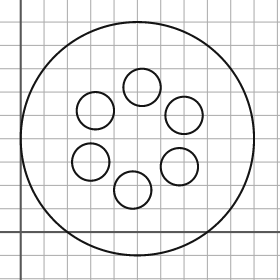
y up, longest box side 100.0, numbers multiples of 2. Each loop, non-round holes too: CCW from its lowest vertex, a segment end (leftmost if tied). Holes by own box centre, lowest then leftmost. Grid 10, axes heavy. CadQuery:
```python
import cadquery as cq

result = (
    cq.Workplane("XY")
    .moveTo(50.0, 40.0)
    .circle(50.0)
    .moveTo(48.0, 18.0)
    .circle(8.0)
    .moveTo(68.0, 28.0)
    .circle(8.0)
    .moveTo(30.0, 30.0)
    .circle(8.0)
    .moveTo(70.0, 50.0)
    .circle(8.0)
    .moveTo(32.0, 52.0)
    .circle(8.0)
    .moveTo(52.0, 62.0)
    .circle(8.0)
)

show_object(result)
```